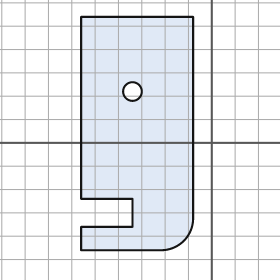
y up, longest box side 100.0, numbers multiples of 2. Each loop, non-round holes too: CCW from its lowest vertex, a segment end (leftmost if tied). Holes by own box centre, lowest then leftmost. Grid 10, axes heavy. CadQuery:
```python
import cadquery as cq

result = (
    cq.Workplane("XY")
    .moveTo(-56.0, -46.0)
    .lineTo(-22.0, -46.0)
    .threePointArc((-12.0, -42.0), (-8.0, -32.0))
    .lineTo(-8.0, 54.0)
    .lineTo(-56.0, 54.0)
    .lineTo(-56.0, -24.0)
    .lineTo(-34.0, -24.0)
    .lineTo(-34.0, -36.0)
    .lineTo(-56.0, -36.0)
    .close()
    .moveTo(-34.0, 22.0)
    .circle(4.0)
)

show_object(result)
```